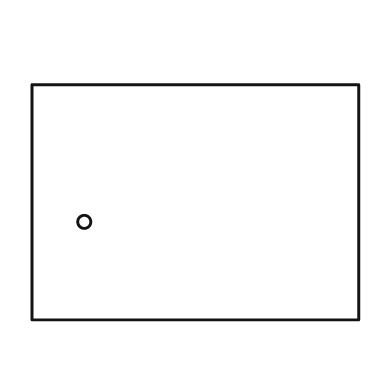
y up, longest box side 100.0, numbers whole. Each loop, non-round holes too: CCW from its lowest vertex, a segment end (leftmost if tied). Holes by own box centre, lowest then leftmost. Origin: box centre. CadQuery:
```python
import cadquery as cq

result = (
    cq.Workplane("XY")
    .moveTo(-50.0, -36.0)
    .lineTo(50.0, -36.0)
    .lineTo(50.0, 36.0)
    .lineTo(-50.0, 36.0)
    .close()
    .moveTo(-34.0, -6.0)
    .circle(2.0)
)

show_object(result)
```